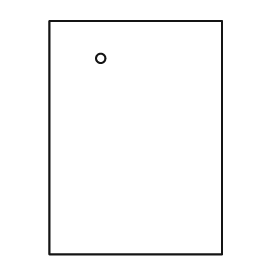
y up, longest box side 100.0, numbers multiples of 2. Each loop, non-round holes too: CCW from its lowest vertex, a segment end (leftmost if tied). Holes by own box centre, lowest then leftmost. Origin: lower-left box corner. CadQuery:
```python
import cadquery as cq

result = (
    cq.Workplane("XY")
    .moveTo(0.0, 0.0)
    .lineTo(74.0, 0.0)
    .lineTo(74.0, 100.0)
    .lineTo(0.0, 100.0)
    .close()
    .moveTo(22.0, 84.0)
    .circle(2.0)
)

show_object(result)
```